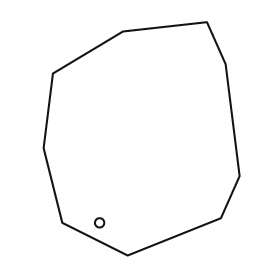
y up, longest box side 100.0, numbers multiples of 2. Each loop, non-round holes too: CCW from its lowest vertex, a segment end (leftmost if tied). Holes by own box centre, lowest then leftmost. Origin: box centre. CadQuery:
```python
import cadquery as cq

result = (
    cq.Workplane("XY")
    .moveTo(-6.0, -50.0)
    .lineTo(34.0, -34.0)
    .lineTo(42.0, -16.0)
    .lineTo(36.0, 32.0)
    .lineTo(28.0, 50.0)
    .lineTo(-8.0, 46.0)
    .lineTo(-38.0, 28.0)
    .lineTo(-42.0, -4.0)
    .lineTo(-34.0, -36.0)
    .close()
    .moveTo(-18.0, -36.0)
    .circle(2.0)
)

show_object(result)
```